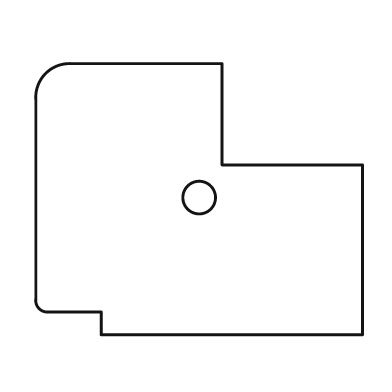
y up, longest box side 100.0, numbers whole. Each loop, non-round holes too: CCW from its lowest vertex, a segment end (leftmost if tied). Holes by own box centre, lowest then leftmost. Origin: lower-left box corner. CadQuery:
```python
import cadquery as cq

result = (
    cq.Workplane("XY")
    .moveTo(20.0, 0.0)
    .lineTo(100.0, 0.0)
    .lineTo(100.0, 52.0)
    .lineTo(57.0, 52.0)
    .lineTo(57.0, 83.0)
    .lineTo(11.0, 83.0)
    .threePointArc((3.0, 80.0), (0.0, 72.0))
    .lineTo(0.0, 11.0)
    .threePointArc((1.0, 8.0), (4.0, 7.0))
    .lineTo(20.0, 7.0)
    .close()
    .moveTo(50.0, 42.0)
    .circle(5.0)
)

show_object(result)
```